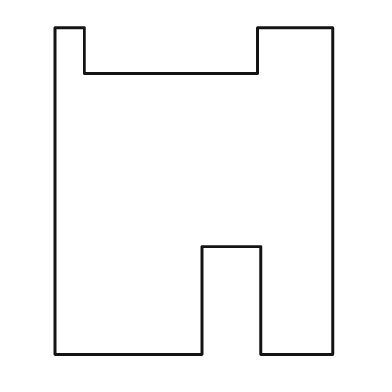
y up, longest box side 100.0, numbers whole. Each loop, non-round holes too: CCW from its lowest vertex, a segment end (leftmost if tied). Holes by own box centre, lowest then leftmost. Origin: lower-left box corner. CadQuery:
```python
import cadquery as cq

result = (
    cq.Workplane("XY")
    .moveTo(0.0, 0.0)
    .lineTo(45.0, 0.0)
    .lineTo(45.0, 33.0)
    .lineTo(63.0, 33.0)
    .lineTo(63.0, 0.0)
    .lineTo(85.0, 0.0)
    .lineTo(85.0, 100.0)
    .lineTo(62.0, 100.0)
    .lineTo(62.0, 86.0)
    .lineTo(9.0, 86.0)
    .lineTo(9.0, 100.0)
    .lineTo(0.0, 100.0)
    .close()
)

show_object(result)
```